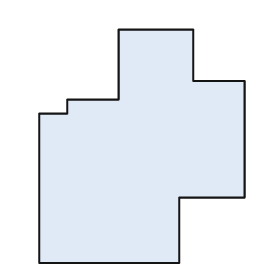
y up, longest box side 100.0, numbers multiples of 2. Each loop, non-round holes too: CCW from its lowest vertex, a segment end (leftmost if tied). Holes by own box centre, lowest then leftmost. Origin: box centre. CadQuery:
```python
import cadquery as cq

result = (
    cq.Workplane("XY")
    .moveTo(-44.0, -50.0)
    .lineTo(16.0, -50.0)
    .lineTo(16.0, -22.0)
    .lineTo(44.0, -22.0)
    .lineTo(44.0, 28.0)
    .lineTo(22.0, 28.0)
    .lineTo(22.0, 50.0)
    .lineTo(-10.0, 50.0)
    .lineTo(-10.0, 20.0)
    .lineTo(-32.0, 20.0)
    .lineTo(-32.0, 14.0)
    .lineTo(-44.0, 14.0)
    .close()
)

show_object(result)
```